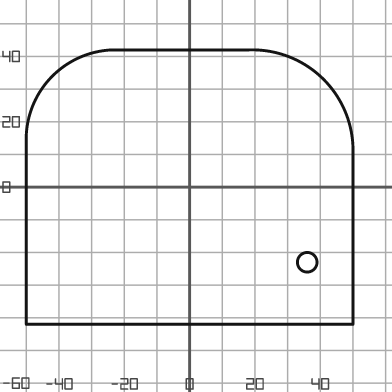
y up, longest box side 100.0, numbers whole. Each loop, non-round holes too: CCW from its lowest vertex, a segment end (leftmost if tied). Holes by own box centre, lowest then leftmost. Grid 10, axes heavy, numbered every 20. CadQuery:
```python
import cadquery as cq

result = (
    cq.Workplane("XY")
    .moveTo(-50.0, -42.0)
    .lineTo(50.0, -42.0)
    .lineTo(50.0, 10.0)
    .threePointArc((41.0, 33.0), (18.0, 42.0))
    .lineTo(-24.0, 42.0)
    .threePointArc((-42.0, 34.0), (-50.0, 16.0))
    .close()
    .moveTo(36.0, -23.0)
    .circle(3.0)
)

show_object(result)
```